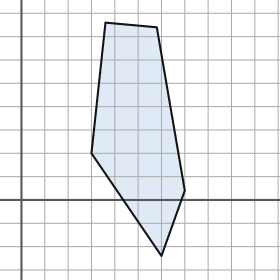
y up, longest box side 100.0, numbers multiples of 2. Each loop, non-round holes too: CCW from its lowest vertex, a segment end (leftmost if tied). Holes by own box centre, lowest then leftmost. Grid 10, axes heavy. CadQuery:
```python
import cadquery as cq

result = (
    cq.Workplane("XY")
    .moveTo(60.0, -24.0)
    .lineTo(70.0, 4.0)
    .lineTo(58.0, 74.0)
    .lineTo(36.0, 76.0)
    .lineTo(30.0, 20.0)
    .close()
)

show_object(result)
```